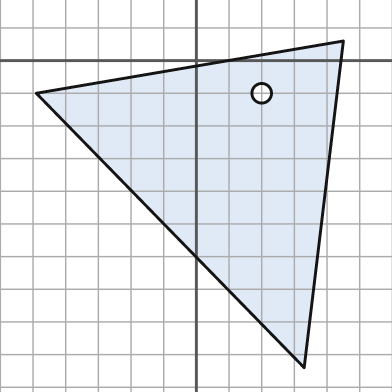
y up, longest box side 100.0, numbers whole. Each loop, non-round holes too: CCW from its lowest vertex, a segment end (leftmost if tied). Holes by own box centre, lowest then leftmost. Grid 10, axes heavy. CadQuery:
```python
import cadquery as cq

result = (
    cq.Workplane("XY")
    .moveTo(33.0, -94.0)
    .lineTo(45.0, 6.0)
    .lineTo(-49.0, -10.0)
    .close()
    .moveTo(20.0, -10.0)
    .circle(3.0)
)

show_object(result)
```